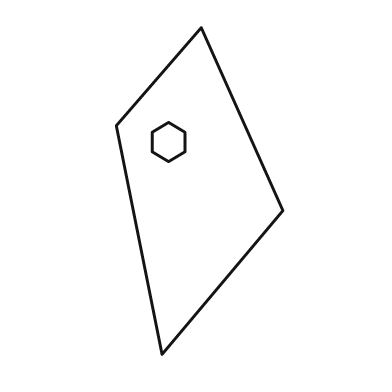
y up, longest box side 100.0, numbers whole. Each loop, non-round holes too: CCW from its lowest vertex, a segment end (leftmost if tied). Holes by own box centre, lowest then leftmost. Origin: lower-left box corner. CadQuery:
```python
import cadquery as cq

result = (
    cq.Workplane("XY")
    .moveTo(14.0, 0.0)
    .lineTo(51.0, 44.0)
    .lineTo(26.0, 100.0)
    .lineTo(0.0, 70.0)
    .close()
    .moveTo(16.0, 59.0)
    .lineTo(21.0, 62.0)
    .lineTo(21.0, 68.0)
    .lineTo(16.0, 71.0)
    .lineTo(11.0, 68.0)
    .lineTo(11.0, 62.0)
    .close()
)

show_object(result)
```